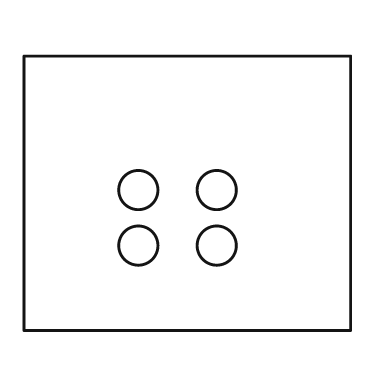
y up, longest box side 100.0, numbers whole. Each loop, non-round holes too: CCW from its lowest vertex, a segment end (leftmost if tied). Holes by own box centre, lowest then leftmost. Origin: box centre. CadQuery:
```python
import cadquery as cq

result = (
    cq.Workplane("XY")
    .moveTo(-50.0, -42.0)
    .lineTo(50.0, -42.0)
    .lineTo(50.0, 42.0)
    .lineTo(-50.0, 42.0)
    .close()
    .moveTo(-15.0, -16.0)
    .circle(6.0)
    .moveTo(9.0, -16.0)
    .circle(6.0)
    .moveTo(-15.0, 1.0)
    .circle(6.0)
    .moveTo(9.0, 1.0)
    .circle(6.0)
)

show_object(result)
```